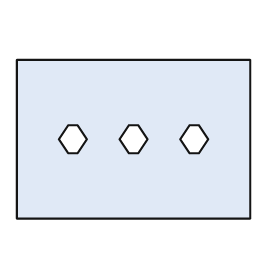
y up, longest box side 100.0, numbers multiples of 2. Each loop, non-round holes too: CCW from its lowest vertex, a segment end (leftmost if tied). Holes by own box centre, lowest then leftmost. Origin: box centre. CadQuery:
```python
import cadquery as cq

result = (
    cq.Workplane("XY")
    .moveTo(-50.0, -34.0)
    .lineTo(50.0, -34.0)
    .lineTo(50.0, 34.0)
    .lineTo(-50.0, 34.0)
    .close()
    .moveTo(-28.0, -6.0)
    .lineTo(-24.0, -6.0)
    .lineTo(-20.0, 0.0)
    .lineTo(-24.0, 6.0)
    .lineTo(-28.0, 6.0)
    .lineTo(-32.0, 0.0)
    .close()
    .moveTo(-2.0, -6.0)
    .lineTo(2.0, -6.0)
    .lineTo(6.0, 0.0)
    .lineTo(2.0, 6.0)
    .lineTo(-2.0, 6.0)
    .lineTo(-6.0, 0.0)
    .close()
    .moveTo(24.0, -6.0)
    .lineTo(28.0, -6.0)
    .lineTo(32.0, 0.0)
    .lineTo(28.0, 6.0)
    .lineTo(24.0, 6.0)
    .lineTo(20.0, 0.0)
    .close()
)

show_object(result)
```